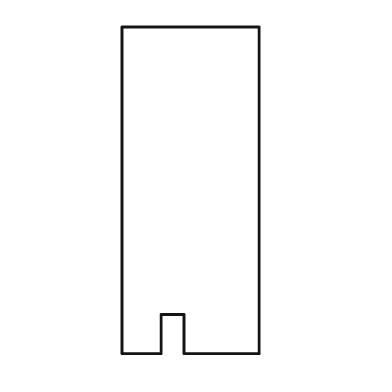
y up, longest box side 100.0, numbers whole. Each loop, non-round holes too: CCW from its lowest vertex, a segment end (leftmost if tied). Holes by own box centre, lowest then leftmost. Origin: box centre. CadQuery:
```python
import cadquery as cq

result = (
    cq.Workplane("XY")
    .moveTo(-21.0, -50.0)
    .lineTo(-9.0, -50.0)
    .lineTo(-9.0, -38.0)
    .lineTo(-2.0, -38.0)
    .lineTo(-2.0, -50.0)
    .lineTo(21.0, -50.0)
    .lineTo(21.0, 50.0)
    .lineTo(-21.0, 50.0)
    .close()
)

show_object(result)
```